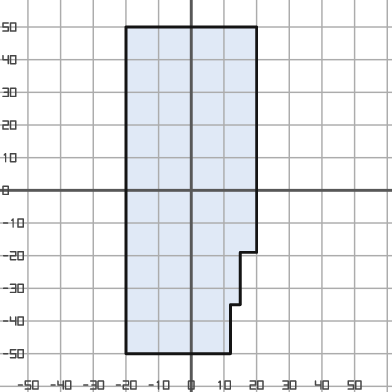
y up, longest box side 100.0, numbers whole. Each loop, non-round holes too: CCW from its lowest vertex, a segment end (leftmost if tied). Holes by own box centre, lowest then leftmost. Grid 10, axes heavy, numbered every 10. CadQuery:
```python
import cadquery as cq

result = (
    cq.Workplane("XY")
    .moveTo(-20.0, -50.0)
    .lineTo(12.0, -50.0)
    .lineTo(12.0, -35.0)
    .lineTo(15.0, -35.0)
    .lineTo(15.0, -19.0)
    .lineTo(20.0, -19.0)
    .lineTo(20.0, 50.0)
    .lineTo(-20.0, 50.0)
    .close()
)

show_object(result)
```